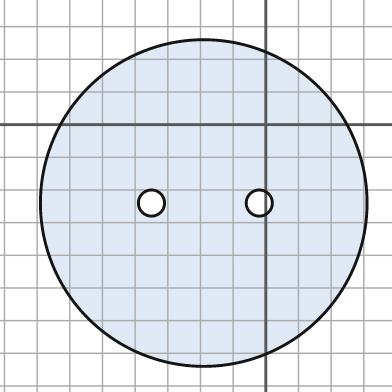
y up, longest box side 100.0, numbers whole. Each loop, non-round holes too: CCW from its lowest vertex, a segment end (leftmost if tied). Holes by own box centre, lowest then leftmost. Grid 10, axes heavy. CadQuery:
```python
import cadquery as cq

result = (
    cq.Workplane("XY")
    .moveTo(-19.0, -24.0)
    .circle(50.0)
    .moveTo(-35.0, -24.0)
    .circle(4.0)
    .moveTo(-2.0, -24.0)
    .circle(4.0)
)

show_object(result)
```